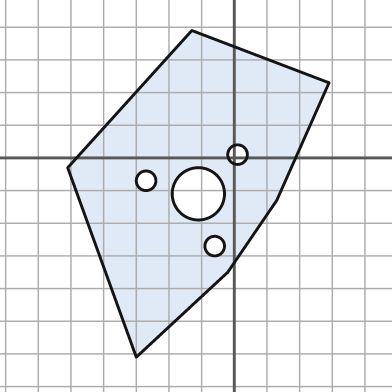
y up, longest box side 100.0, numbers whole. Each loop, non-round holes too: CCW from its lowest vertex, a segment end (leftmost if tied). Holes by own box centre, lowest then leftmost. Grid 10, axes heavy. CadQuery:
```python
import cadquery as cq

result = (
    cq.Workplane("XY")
    .moveTo(-30.0, -61.0)
    .lineTo(-2.0, -35.0)
    .lineTo(13.0, -13.0)
    .lineTo(29.0, 23.0)
    .lineTo(-13.0, 39.0)
    .lineTo(-51.0, -3.0)
    .close()
    .moveTo(-6.0, -27.0)
    .circle(3.0)
    .moveTo(-11.0, -11.0)
    .circle(8.0)
    .moveTo(-27.0, -7.0)
    .circle(3.0)
    .moveTo(1.0, 1.0)
    .circle(3.0)
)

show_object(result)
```